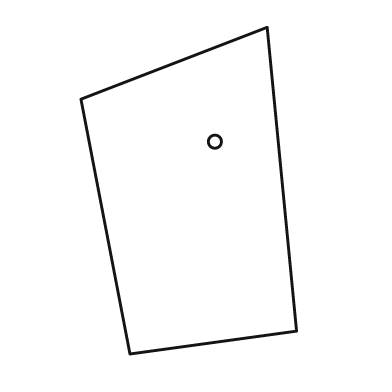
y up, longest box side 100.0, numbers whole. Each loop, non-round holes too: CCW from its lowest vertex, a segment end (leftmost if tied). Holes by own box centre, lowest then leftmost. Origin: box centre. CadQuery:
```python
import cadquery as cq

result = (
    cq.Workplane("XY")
    .moveTo(-18.0, -50.0)
    .lineTo(33.0, -43.0)
    .lineTo(24.0, 50.0)
    .lineTo(-33.0, 28.0)
    .close()
    .moveTo(8.0, 15.0)
    .circle(2.0)
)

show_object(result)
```